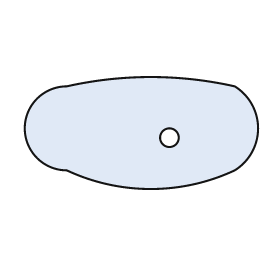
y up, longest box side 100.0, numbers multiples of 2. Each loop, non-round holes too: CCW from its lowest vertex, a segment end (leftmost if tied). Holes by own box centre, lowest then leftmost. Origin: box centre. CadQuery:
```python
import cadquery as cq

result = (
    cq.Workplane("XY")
    .moveTo(-32.0, -16.0)
    .threePointArc((4.0, -24.0), (40.0, -16.0))
    .threePointArc((50.0, 2.0), (40.0, 20.0))
    .threePointArc((4.0, 24.0), (-32.0, 20.0))
    .threePointArc((-50.0, 2.0), (-32.0, -16.0))
    .close()
    .moveTo(12.0, -2.0)
    .circle(4.0)
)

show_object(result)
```